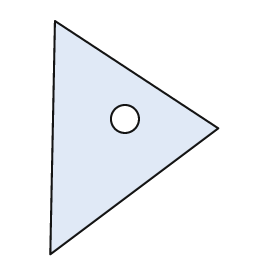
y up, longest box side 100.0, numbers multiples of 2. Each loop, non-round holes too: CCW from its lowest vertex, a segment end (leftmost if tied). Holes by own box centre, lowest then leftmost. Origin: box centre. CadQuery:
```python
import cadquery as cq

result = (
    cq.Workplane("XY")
    .moveTo(-36.0, -50.0)
    .lineTo(36.0, 4.0)
    .lineTo(-34.0, 50.0)
    .close()
    .moveTo(-4.0, 8.0)
    .circle(6.0)
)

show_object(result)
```